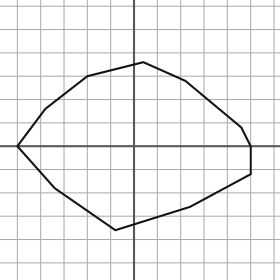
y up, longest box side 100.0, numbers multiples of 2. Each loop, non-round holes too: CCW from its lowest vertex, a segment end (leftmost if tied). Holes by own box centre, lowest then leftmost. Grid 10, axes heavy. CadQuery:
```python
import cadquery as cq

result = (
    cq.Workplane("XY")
    .moveTo(-8.0, -36.0)
    .lineTo(24.0, -26.0)
    .lineTo(50.0, -12.0)
    .lineTo(50.0, 0.0)
    .lineTo(46.0, 8.0)
    .lineTo(22.0, 28.0)
    .lineTo(4.0, 36.0)
    .lineTo(-20.0, 30.0)
    .lineTo(-38.0, 16.0)
    .lineTo(-50.0, 0.0)
    .lineTo(-34.0, -18.0)
    .close()
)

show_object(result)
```